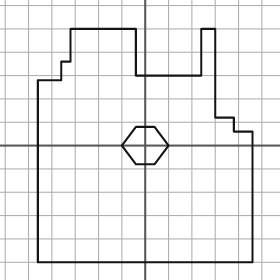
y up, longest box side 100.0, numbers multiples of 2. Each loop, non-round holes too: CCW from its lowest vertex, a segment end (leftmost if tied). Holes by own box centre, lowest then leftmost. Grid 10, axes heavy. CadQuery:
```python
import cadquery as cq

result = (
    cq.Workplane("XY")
    .moveTo(-46.0, -50.0)
    .lineTo(46.0, -50.0)
    .lineTo(46.0, 6.0)
    .lineTo(38.0, 6.0)
    .lineTo(38.0, 12.0)
    .lineTo(30.0, 12.0)
    .lineTo(30.0, 50.0)
    .lineTo(24.0, 50.0)
    .lineTo(24.0, 30.0)
    .lineTo(-4.0, 30.0)
    .lineTo(-4.0, 50.0)
    .lineTo(-32.0, 50.0)
    .lineTo(-32.0, 36.0)
    .lineTo(-36.0, 36.0)
    .lineTo(-36.0, 28.0)
    .lineTo(-46.0, 28.0)
    .close()
    .moveTo(-4.0, -8.0)
    .lineTo(4.0, -8.0)
    .lineTo(10.0, 0.0)
    .lineTo(4.0, 8.0)
    .lineTo(-4.0, 8.0)
    .lineTo(-10.0, 0.0)
    .close()
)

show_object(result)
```